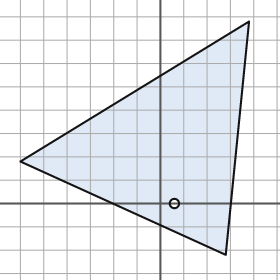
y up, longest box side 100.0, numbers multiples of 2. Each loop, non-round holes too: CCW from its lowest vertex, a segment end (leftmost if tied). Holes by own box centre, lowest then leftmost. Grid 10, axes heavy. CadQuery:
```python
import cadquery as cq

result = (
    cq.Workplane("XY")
    .moveTo(28.0, -22.0)
    .lineTo(38.0, 78.0)
    .lineTo(-60.0, 18.0)
    .close()
    .moveTo(6.0, 0.0)
    .circle(2.0)
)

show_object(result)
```